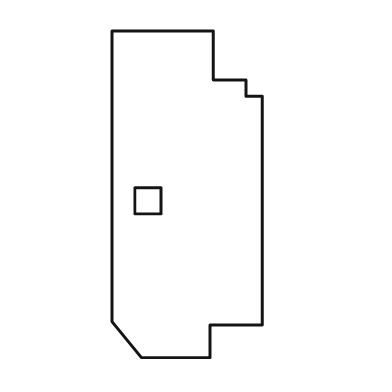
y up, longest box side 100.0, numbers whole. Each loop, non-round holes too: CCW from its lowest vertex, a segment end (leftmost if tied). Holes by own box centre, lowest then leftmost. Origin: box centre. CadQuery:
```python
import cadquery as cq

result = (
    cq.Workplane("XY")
    .moveTo(-14.0, -50.0)
    .lineTo(7.0, -50.0)
    .lineTo(7.0, -40.0)
    .lineTo(23.0, -40.0)
    .lineTo(23.0, 30.0)
    .lineTo(18.0, 30.0)
    .lineTo(18.0, 35.0)
    .lineTo(8.0, 35.0)
    .lineTo(8.0, 50.0)
    .lineTo(-23.0, 50.0)
    .lineTo(-23.0, -39.0)
    .close()
    .moveTo(-16.0, -6.0)
    .lineTo(-8.0, -6.0)
    .lineTo(-8.0, 2.0)
    .lineTo(-16.0, 2.0)
    .close()
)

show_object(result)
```